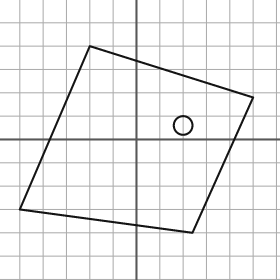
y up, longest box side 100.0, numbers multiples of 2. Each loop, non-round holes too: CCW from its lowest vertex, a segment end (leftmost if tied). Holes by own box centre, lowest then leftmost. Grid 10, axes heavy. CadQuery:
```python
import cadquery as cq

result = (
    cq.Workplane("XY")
    .moveTo(24.0, -40.0)
    .lineTo(50.0, 18.0)
    .lineTo(-20.0, 40.0)
    .lineTo(-50.0, -30.0)
    .close()
    .moveTo(20.0, 6.0)
    .circle(4.0)
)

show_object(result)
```